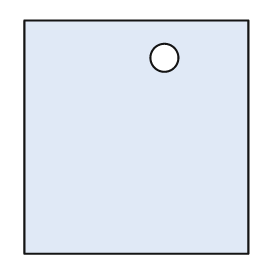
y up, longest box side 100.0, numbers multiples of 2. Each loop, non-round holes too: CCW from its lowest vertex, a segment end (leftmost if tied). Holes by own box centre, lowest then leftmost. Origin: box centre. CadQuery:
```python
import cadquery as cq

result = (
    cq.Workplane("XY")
    .moveTo(-48.0, -50.0)
    .lineTo(48.0, -50.0)
    .lineTo(48.0, 50.0)
    .lineTo(-48.0, 50.0)
    .close()
    .moveTo(12.0, 34.0)
    .circle(6.0)
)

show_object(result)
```